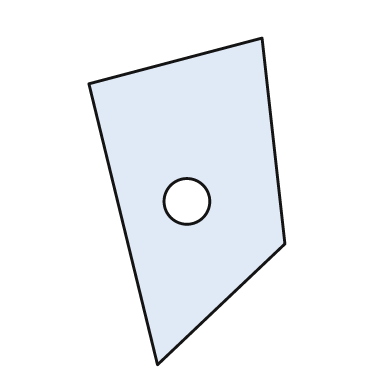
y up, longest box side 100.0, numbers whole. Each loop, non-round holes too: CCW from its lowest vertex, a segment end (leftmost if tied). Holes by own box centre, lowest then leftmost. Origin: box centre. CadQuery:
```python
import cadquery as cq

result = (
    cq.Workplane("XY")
    .moveTo(-9.0, -50.0)
    .lineTo(30.0, -13.0)
    .lineTo(23.0, 50.0)
    .lineTo(-30.0, 36.0)
    .close()
    .moveTo(0.0, 0.0)
    .circle(7.0)
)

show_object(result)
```